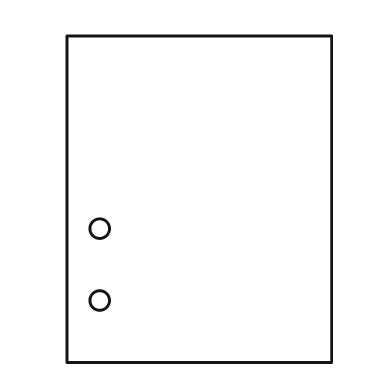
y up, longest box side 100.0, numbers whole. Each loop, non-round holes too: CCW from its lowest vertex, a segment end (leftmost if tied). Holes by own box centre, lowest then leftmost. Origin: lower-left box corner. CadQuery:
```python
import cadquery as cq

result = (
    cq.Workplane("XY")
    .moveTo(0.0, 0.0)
    .lineTo(81.0, 0.0)
    .lineTo(81.0, 100.0)
    .lineTo(0.0, 100.0)
    .close()
    .moveTo(10.0, 19.0)
    .circle(3.0)
    .moveTo(10.0, 41.0)
    .circle(3.0)
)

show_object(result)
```